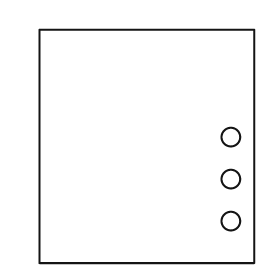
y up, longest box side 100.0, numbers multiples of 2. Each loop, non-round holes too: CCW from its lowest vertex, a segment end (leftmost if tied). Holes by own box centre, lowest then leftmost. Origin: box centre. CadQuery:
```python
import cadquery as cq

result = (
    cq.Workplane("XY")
    .moveTo(-46.0, -50.0)
    .lineTo(46.0, -50.0)
    .lineTo(46.0, 50.0)
    .lineTo(-46.0, 50.0)
    .close()
    .moveTo(36.0, -32.0)
    .circle(4.0)
    .moveTo(36.0, -14.0)
    .circle(4.0)
    .moveTo(36.0, 4.0)
    .circle(4.0)
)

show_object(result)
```